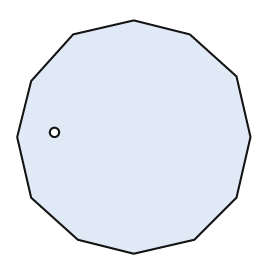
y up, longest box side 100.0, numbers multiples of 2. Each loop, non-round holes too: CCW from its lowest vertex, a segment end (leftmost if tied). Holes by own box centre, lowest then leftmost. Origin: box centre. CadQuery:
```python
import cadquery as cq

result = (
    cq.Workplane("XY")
    .moveTo(0.0, -50.0)
    .lineTo(26.0, -44.0)
    .lineTo(44.0, -26.0)
    .lineTo(50.0, 0.0)
    .lineTo(44.0, 26.0)
    .lineTo(24.0, 44.0)
    .lineTo(0.0, 50.0)
    .lineTo(-26.0, 44.0)
    .lineTo(-44.0, 24.0)
    .lineTo(-50.0, 0.0)
    .lineTo(-44.0, -26.0)
    .lineTo(-24.0, -44.0)
    .close()
    .moveTo(-34.0, 2.0)
    .circle(2.0)
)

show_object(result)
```